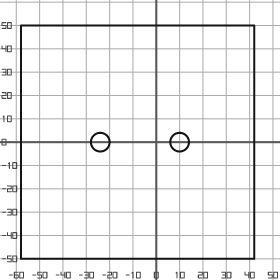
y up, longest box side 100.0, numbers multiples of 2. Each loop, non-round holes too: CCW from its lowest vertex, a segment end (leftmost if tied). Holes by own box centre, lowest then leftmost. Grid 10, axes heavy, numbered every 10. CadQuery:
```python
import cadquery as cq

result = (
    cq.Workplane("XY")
    .moveTo(-58.0, -50.0)
    .lineTo(42.0, -50.0)
    .lineTo(42.0, 50.0)
    .lineTo(-58.0, 50.0)
    .close()
    .moveTo(-24.0, 0.0)
    .circle(4.0)
    .moveTo(10.0, 0.0)
    .circle(4.0)
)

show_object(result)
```